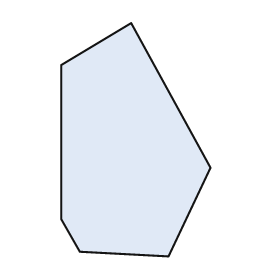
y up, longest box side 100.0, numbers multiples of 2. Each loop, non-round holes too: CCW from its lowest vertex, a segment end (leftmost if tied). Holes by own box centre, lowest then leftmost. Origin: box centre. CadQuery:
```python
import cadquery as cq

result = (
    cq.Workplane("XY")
    .moveTo(14.0, -50.0)
    .lineTo(32.0, -12.0)
    .lineTo(-2.0, 50.0)
    .lineTo(-32.0, 32.0)
    .lineTo(-32.0, -34.0)
    .lineTo(-24.0, -48.0)
    .close()
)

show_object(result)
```